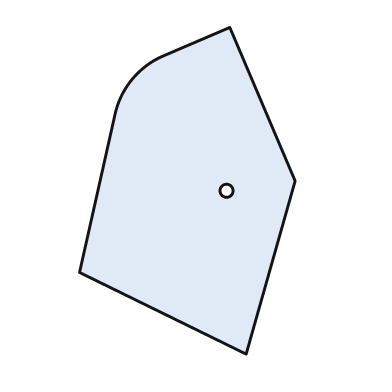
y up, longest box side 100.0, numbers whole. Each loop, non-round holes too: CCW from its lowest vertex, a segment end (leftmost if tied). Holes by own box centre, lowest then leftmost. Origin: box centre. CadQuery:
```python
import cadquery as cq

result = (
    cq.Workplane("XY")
    .moveTo(18.0, -50.0)
    .lineTo(33.0, 3.0)
    .lineTo(13.0, 50.0)
    .lineTo(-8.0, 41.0)
    .threePointArc((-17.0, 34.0), (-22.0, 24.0))
    .lineTo(-33.0, -25.0)
    .close()
    .moveTo(12.0, 0.0)
    .circle(2.0)
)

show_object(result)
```